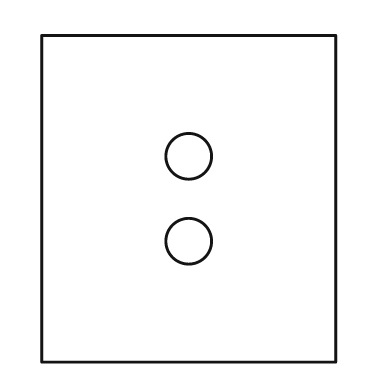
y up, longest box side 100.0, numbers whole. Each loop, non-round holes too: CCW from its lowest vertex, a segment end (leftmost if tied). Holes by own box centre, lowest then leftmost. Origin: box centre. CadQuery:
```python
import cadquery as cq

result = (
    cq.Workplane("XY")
    .moveTo(-45.0, -50.0)
    .lineTo(45.0, -50.0)
    .lineTo(45.0, 50.0)
    .lineTo(-45.0, 50.0)
    .close()
    .moveTo(0.0, -13.0)
    .circle(7.0)
    .moveTo(0.0, 13.0)
    .circle(7.0)
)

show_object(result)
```